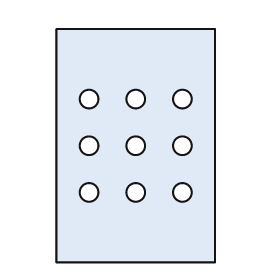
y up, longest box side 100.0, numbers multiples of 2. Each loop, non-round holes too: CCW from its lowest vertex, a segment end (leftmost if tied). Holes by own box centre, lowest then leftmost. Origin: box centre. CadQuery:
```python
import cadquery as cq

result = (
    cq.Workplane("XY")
    .moveTo(-34.0, -50.0)
    .lineTo(34.0, -50.0)
    .lineTo(34.0, 50.0)
    .lineTo(-34.0, 50.0)
    .close()
    .moveTo(-20.0, -20.0)
    .circle(4.0)
    .moveTo(0.0, -20.0)
    .circle(4.0)
    .moveTo(20.0, -20.0)
    .circle(4.0)
    .moveTo(-20.0, 0.0)
    .circle(4.0)
    .moveTo(0.0, 0.0)
    .circle(4.0)
    .moveTo(20.0, 0.0)
    .circle(4.0)
    .moveTo(-20.0, 20.0)
    .circle(4.0)
    .moveTo(0.0, 20.0)
    .circle(4.0)
    .moveTo(20.0, 20.0)
    .circle(4.0)
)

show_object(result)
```